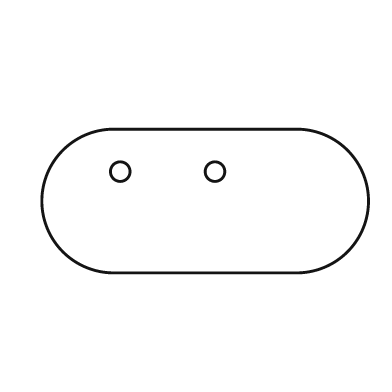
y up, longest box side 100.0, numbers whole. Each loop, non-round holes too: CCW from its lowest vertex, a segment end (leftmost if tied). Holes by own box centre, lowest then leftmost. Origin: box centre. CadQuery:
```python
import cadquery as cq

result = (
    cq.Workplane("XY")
    .moveTo(-28.0, -22.0)
    .lineTo(28.0, -22.0)
    .threePointArc((50.0, 0.0), (28.0, 22.0))
    .lineTo(-28.0, 22.0)
    .threePointArc((-50.0, 0.0), (-28.0, -22.0))
    .close()
    .moveTo(-26.0, 9.0)
    .circle(3.0)
    .moveTo(3.0, 9.0)
    .circle(3.0)
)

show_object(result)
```